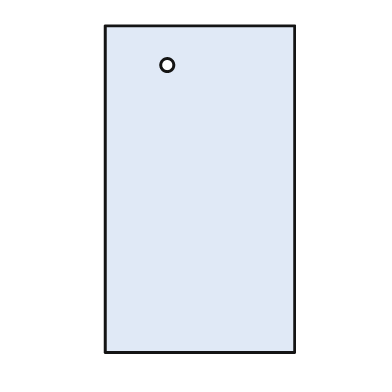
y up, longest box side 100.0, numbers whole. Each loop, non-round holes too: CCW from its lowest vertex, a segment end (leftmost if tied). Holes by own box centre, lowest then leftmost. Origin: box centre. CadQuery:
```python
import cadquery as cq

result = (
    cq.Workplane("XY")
    .moveTo(-29.0, -50.0)
    .lineTo(29.0, -50.0)
    .lineTo(29.0, 50.0)
    .lineTo(-29.0, 50.0)
    .close()
    .moveTo(-10.0, 38.0)
    .circle(2.0)
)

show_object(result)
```